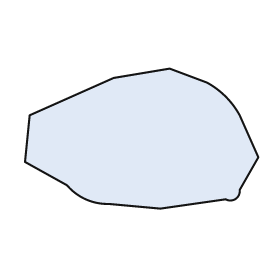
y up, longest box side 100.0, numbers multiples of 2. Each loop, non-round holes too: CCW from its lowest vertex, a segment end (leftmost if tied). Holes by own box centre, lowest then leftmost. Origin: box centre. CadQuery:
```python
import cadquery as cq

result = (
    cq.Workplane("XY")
    .moveTo(8.0, -30.0)
    .lineTo(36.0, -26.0)
    .threePointArc((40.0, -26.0), (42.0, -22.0))
    .lineTo(50.0, -8.0)
    .lineTo(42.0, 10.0)
    .threePointArc((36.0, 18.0), (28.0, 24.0))
    .lineTo(12.0, 30.0)
    .lineTo(-12.0, 26.0)
    .lineTo(-48.0, 10.0)
    .lineTo(-50.0, -10.0)
    .lineTo(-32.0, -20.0)
    .threePointArc((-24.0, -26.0), (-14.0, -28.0))
    .close()
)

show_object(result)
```